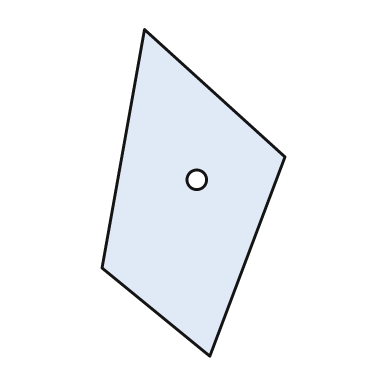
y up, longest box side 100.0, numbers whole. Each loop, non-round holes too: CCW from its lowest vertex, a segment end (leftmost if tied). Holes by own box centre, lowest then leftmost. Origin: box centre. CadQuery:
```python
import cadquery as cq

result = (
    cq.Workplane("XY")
    .moveTo(5.0, -50.0)
    .lineTo(28.0, 11.0)
    .lineTo(-15.0, 50.0)
    .lineTo(-28.0, -23.0)
    .close()
    .moveTo(1.0, 4.0)
    .circle(3.0)
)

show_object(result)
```